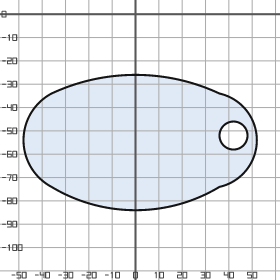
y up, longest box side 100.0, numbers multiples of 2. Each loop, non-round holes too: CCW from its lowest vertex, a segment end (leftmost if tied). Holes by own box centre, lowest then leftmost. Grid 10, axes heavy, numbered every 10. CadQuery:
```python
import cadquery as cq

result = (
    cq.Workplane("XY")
    .moveTo(-36.0, -74.0)
    .threePointArc((0.0, -84.0), (36.0, -74.0))
    .threePointArc((52.0, -54.0), (36.0, -34.0))
    .threePointArc((0.0, -26.0), (-36.0, -34.0))
    .threePointArc((-48.0, -54.0), (-36.0, -74.0))
    .close()
    .moveTo(42.0, -52.0)
    .circle(6.0)
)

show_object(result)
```